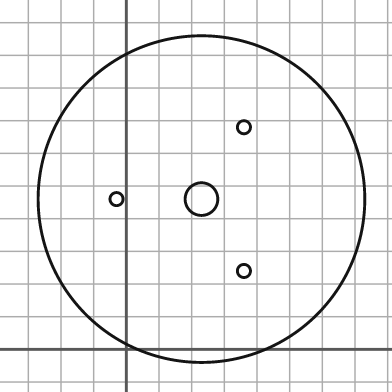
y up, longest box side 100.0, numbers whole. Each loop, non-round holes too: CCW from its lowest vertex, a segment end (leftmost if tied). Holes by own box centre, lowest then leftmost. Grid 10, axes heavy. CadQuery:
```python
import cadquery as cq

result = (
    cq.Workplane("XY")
    .moveTo(23.0, 46.0)
    .circle(50.0)
    .moveTo(36.0, 24.0)
    .circle(2.0)
    .moveTo(-3.0, 46.0)
    .circle(2.0)
    .moveTo(23.0, 46.0)
    .circle(5.0)
    .moveTo(36.0, 68.0)
    .circle(2.0)
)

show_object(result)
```